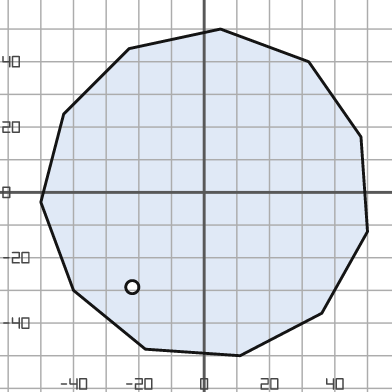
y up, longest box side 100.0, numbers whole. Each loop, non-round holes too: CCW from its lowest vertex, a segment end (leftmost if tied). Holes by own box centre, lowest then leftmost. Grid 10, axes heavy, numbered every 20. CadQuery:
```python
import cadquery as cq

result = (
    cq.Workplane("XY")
    .moveTo(11.0, -50.0)
    .lineTo(36.0, -37.0)
    .lineTo(50.0, -12.0)
    .lineTo(48.0, 17.0)
    .lineTo(32.0, 40.0)
    .lineTo(5.0, 50.0)
    .lineTo(-23.0, 44.0)
    .lineTo(-43.0, 24.0)
    .lineTo(-50.0, -3.0)
    .lineTo(-40.0, -30.0)
    .lineTo(-18.0, -48.0)
    .close()
    .moveTo(-22.0, -29.0)
    .circle(2.0)
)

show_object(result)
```